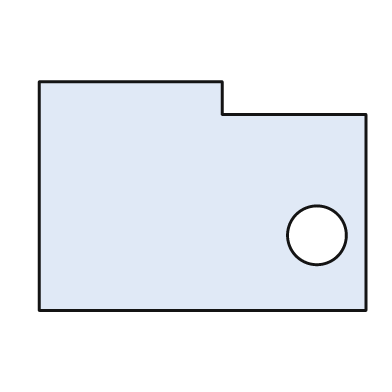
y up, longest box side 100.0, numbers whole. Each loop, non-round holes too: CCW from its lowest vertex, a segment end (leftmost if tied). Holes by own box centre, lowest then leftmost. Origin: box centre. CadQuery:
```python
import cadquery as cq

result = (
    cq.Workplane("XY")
    .moveTo(-50.0, -35.0)
    .lineTo(50.0, -35.0)
    .lineTo(50.0, 25.0)
    .lineTo(6.0, 25.0)
    .lineTo(6.0, 35.0)
    .lineTo(-50.0, 35.0)
    .close()
    .moveTo(35.0, -12.0)
    .circle(9.0)
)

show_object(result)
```